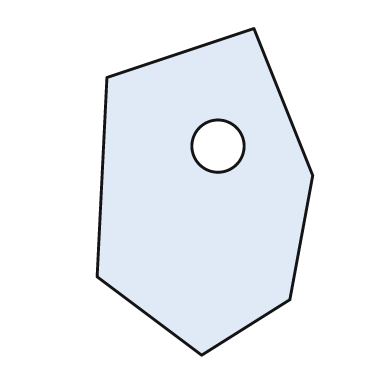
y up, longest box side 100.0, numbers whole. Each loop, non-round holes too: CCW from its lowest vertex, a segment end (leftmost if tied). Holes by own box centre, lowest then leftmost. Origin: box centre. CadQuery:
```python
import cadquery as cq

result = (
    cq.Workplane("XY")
    .moveTo(-1.0, -50.0)
    .lineTo(26.0, -33.0)
    .lineTo(33.0, 5.0)
    .lineTo(15.0, 50.0)
    .lineTo(-30.0, 35.0)
    .lineTo(-33.0, -26.0)
    .close()
    .moveTo(4.0, 14.0)
    .circle(8.0)
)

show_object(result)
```